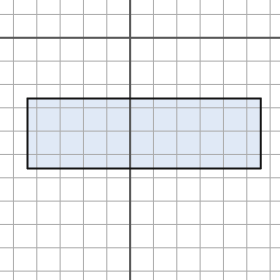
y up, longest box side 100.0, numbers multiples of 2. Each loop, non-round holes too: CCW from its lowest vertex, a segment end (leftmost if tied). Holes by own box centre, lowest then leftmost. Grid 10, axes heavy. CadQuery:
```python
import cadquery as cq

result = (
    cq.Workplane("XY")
    .moveTo(-44.0, -56.0)
    .lineTo(56.0, -56.0)
    .lineTo(56.0, -26.0)
    .lineTo(-44.0, -26.0)
    .close()
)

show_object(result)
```